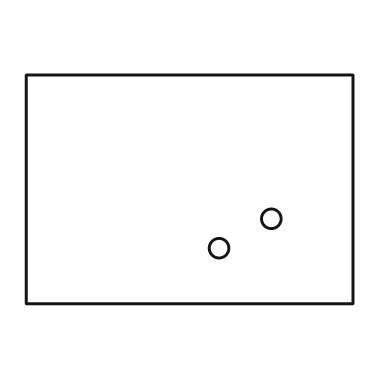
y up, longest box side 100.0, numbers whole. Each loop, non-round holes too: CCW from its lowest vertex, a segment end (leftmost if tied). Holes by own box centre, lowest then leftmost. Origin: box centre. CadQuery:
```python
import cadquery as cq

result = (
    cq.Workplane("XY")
    .moveTo(-50.0, -35.0)
    .lineTo(50.0, -35.0)
    .lineTo(50.0, 35.0)
    .lineTo(-50.0, 35.0)
    .close()
    .moveTo(9.0, -18.0)
    .circle(3.0)
    .moveTo(25.0, -9.0)
    .circle(3.0)
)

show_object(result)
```